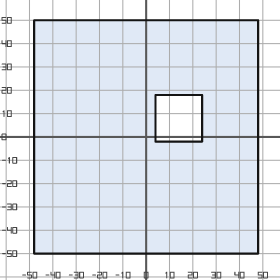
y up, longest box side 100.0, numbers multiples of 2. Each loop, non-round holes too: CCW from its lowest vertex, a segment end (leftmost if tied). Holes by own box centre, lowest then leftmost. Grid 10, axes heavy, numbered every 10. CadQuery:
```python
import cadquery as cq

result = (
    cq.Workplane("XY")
    .moveTo(-48.0, -50.0)
    .lineTo(48.0, -50.0)
    .lineTo(48.0, 50.0)
    .lineTo(-48.0, 50.0)
    .close()
    .moveTo(4.0, -2.0)
    .lineTo(24.0, -2.0)
    .lineTo(24.0, 18.0)
    .lineTo(4.0, 18.0)
    .close()
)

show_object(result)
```